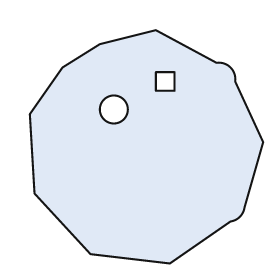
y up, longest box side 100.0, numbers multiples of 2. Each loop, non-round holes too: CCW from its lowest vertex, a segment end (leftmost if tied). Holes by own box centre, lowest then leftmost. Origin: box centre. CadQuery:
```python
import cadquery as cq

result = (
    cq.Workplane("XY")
    .moveTo(10.0, -50.0)
    .lineTo(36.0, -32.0)
    .threePointArc((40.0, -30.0), (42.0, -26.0))
    .lineTo(50.0, 2.0)
    .lineTo(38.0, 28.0)
    .threePointArc((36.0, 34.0), (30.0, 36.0))
    .lineTo(4.0, 50.0)
    .lineTo(-20.0, 44.0)
    .lineTo(-36.0, 34.0)
    .lineTo(-50.0, 14.0)
    .lineTo(-48.0, -20.0)
    .lineTo(-24.0, -46.0)
    .close()
    .moveTo(-14.0, 16.0)
    .circle(6.0)
    .moveTo(4.0, 24.0)
    .lineTo(12.0, 24.0)
    .lineTo(12.0, 32.0)
    .lineTo(4.0, 32.0)
    .close()
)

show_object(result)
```